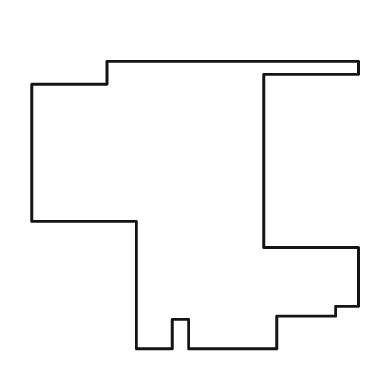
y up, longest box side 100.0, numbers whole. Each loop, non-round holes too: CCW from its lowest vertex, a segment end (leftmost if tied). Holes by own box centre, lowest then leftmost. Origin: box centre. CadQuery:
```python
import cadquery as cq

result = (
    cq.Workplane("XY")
    .moveTo(-18.0, -44.0)
    .lineTo(-7.0, -44.0)
    .lineTo(-7.0, -35.0)
    .lineTo(-2.0, -35.0)
    .lineTo(-2.0, -44.0)
    .lineTo(25.0, -44.0)
    .lineTo(25.0, -34.0)
    .lineTo(43.0, -34.0)
    .lineTo(43.0, -31.0)
    .lineTo(50.0, -31.0)
    .lineTo(50.0, -13.0)
    .lineTo(21.0, -13.0)
    .lineTo(21.0, 40.0)
    .lineTo(50.0, 40.0)
    .lineTo(50.0, 44.0)
    .lineTo(-27.0, 44.0)
    .lineTo(-27.0, 37.0)
    .lineTo(-50.0, 37.0)
    .lineTo(-50.0, -5.0)
    .lineTo(-18.0, -5.0)
    .close()
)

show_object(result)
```